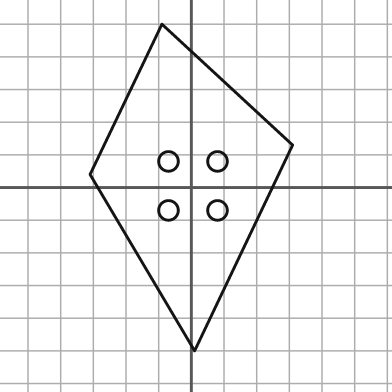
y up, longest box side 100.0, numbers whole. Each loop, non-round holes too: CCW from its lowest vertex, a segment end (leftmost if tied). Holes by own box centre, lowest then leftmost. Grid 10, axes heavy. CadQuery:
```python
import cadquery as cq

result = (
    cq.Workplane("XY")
    .moveTo(1.0, -50.0)
    .lineTo(31.0, 13.0)
    .lineTo(-9.0, 50.0)
    .lineTo(-31.0, 4.0)
    .close()
    .moveTo(-7.0, -7.0)
    .circle(3.0)
    .moveTo(8.0, -7.0)
    .circle(3.0)
    .moveTo(-7.0, 8.0)
    .circle(3.0)
    .moveTo(8.0, 8.0)
    .circle(3.0)
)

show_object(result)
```